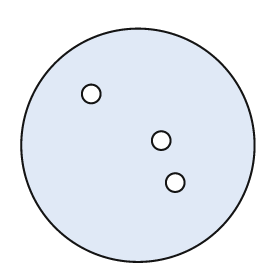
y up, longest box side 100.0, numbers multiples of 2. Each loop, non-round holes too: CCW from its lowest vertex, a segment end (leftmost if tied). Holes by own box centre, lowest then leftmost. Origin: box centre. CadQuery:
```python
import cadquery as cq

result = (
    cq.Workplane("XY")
    .moveTo(0.0, 0.0)
    .circle(50.0)
    .moveTo(16.0, -16.0)
    .circle(4.0)
    .moveTo(10.0, 2.0)
    .circle(4.0)
    .moveTo(-20.0, 22.0)
    .circle(4.0)
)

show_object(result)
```